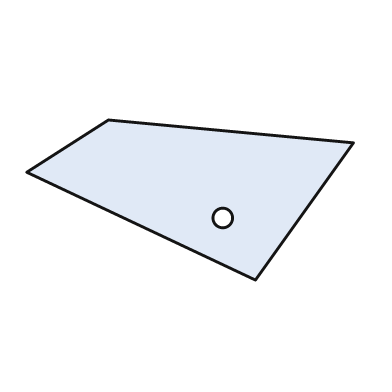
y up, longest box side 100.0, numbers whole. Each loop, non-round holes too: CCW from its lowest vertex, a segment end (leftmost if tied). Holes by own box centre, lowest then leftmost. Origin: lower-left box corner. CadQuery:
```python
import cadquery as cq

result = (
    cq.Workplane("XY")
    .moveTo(70.0, 0.0)
    .lineTo(100.0, 42.0)
    .lineTo(25.0, 49.0)
    .lineTo(0.0, 33.0)
    .close()
    .moveTo(60.0, 19.0)
    .circle(3.0)
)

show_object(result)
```